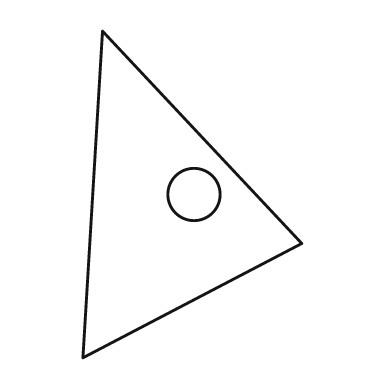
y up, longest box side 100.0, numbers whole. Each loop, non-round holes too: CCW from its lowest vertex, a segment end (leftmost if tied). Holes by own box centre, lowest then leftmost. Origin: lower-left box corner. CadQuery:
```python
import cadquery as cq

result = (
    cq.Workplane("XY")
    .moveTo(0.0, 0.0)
    .lineTo(67.0, 35.0)
    .lineTo(6.0, 100.0)
    .close()
    .moveTo(34.0, 50.0)
    .circle(8.0)
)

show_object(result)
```